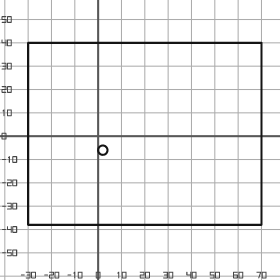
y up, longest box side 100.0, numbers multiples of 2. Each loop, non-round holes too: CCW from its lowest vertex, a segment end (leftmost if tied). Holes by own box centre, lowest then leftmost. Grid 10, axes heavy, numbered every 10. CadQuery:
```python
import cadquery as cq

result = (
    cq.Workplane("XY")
    .moveTo(-30.0, -38.0)
    .lineTo(70.0, -38.0)
    .lineTo(70.0, 40.0)
    .lineTo(-30.0, 40.0)
    .close()
    .moveTo(2.0, -6.0)
    .circle(2.0)
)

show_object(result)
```